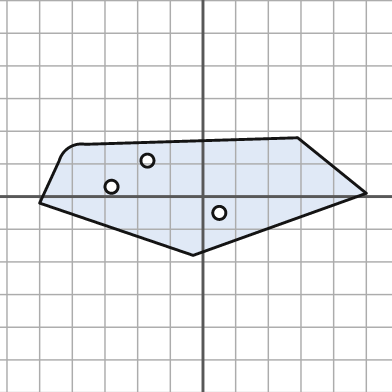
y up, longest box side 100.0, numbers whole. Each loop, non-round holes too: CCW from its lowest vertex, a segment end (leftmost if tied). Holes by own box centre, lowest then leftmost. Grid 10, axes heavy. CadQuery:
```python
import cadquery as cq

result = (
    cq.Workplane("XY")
    .moveTo(-3.0, -18.0)
    .lineTo(50.0, 1.0)
    .lineTo(29.0, 18.0)
    .lineTo(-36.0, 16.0)
    .threePointArc((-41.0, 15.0), (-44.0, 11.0))
    .lineTo(-50.0, -2.0)
    .close()
    .moveTo(5.0, -5.0)
    .circle(2.0)
    .moveTo(-28.0, 3.0)
    .circle(2.0)
    .moveTo(-17.0, 11.0)
    .circle(2.0)
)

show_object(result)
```